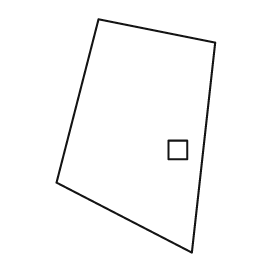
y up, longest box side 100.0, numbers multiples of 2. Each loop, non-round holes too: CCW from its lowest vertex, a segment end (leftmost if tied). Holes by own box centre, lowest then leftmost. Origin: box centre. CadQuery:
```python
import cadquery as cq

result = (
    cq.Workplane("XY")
    .moveTo(24.0, -50.0)
    .lineTo(34.0, 40.0)
    .lineTo(-16.0, 50.0)
    .lineTo(-34.0, -20.0)
    .close()
    .moveTo(14.0, -10.0)
    .lineTo(22.0, -10.0)
    .lineTo(22.0, -2.0)
    .lineTo(14.0, -2.0)
    .close()
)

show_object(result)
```